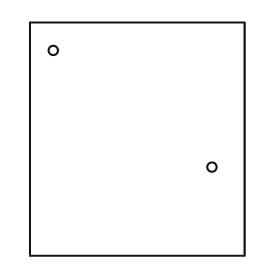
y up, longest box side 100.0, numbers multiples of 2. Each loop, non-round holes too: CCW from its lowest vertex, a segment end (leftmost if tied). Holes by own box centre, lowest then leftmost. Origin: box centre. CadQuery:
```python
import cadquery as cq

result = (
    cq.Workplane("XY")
    .moveTo(-46.0, -50.0)
    .lineTo(46.0, -50.0)
    .lineTo(46.0, 50.0)
    .lineTo(-46.0, 50.0)
    .close()
    .moveTo(32.0, -12.0)
    .circle(2.0)
    .moveTo(-36.0, 38.0)
    .circle(2.0)
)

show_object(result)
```